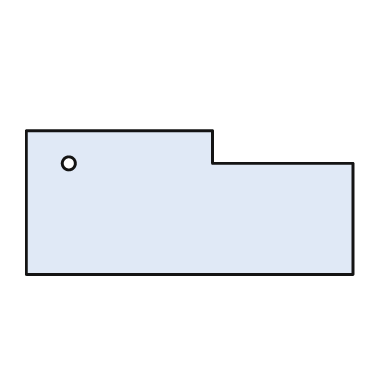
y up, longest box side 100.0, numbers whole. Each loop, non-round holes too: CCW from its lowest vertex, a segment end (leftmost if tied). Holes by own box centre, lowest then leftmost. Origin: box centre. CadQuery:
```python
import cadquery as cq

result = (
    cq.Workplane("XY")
    .moveTo(-50.0, -22.0)
    .lineTo(50.0, -22.0)
    .lineTo(50.0, 12.0)
    .lineTo(7.0, 12.0)
    .lineTo(7.0, 22.0)
    .lineTo(-50.0, 22.0)
    .close()
    .moveTo(-37.0, 12.0)
    .circle(2.0)
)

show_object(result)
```